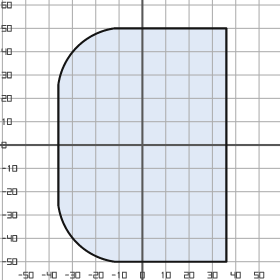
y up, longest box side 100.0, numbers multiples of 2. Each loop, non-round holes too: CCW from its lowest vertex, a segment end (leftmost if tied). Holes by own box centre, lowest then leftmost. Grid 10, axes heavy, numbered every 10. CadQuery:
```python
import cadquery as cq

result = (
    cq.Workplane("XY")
    .moveTo(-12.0, -50.0)
    .lineTo(36.0, -50.0)
    .lineTo(36.0, 50.0)
    .lineTo(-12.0, 50.0)
    .threePointArc((-28.0, 42.0), (-36.0, 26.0))
    .lineTo(-36.0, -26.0)
    .threePointArc((-28.0, -42.0), (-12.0, -50.0))
    .close()
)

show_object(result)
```